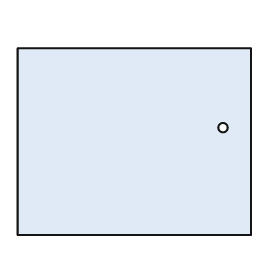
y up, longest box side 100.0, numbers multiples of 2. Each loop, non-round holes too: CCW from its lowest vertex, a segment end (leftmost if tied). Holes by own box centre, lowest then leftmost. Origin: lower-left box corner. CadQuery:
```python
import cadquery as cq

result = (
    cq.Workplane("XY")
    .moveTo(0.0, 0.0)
    .lineTo(100.0, 0.0)
    .lineTo(100.0, 80.0)
    .lineTo(0.0, 80.0)
    .close()
    .moveTo(88.0, 46.0)
    .circle(2.0)
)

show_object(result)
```